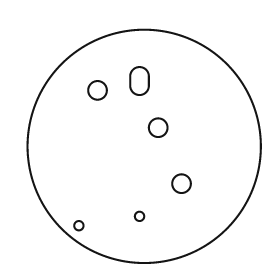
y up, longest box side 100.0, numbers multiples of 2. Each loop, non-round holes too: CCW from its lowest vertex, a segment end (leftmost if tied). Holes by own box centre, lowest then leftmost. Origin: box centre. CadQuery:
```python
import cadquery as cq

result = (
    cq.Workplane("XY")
    .moveTo(0.0, 0.0)
    .circle(50.0)
    .moveTo(-28.0, -34.0)
    .circle(2.0)
    .moveTo(-2.0, -30.0)
    .circle(2.0)
    .moveTo(16.0, -16.0)
    .circle(4.0)
    .moveTo(6.0, 8.0)
    .circle(4.0)
    .moveTo(-20.0, 24.0)
    .circle(4.0)
    .moveTo(-6.0, 26.0)
    .threePointArc((-2.0, 22.0), (2.0, 26.0))
    .lineTo(2.0, 30.0)
    .threePointArc((-2.0, 34.0), (-6.0, 30.0))
    .close()
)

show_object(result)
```